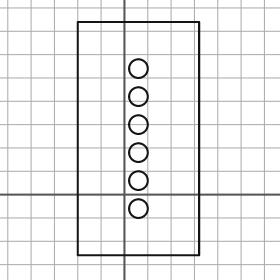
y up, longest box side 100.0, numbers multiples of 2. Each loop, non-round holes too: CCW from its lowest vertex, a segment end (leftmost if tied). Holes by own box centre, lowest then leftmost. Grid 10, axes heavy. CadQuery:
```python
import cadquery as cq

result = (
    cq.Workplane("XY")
    .moveTo(-20.0, -26.0)
    .lineTo(32.0, -26.0)
    .lineTo(32.0, 74.0)
    .lineTo(-20.0, 74.0)
    .close()
    .moveTo(6.0, -6.0)
    .circle(4.0)
    .moveTo(6.0, 6.0)
    .circle(4.0)
    .moveTo(6.0, 18.0)
    .circle(4.0)
    .moveTo(6.0, 30.0)
    .circle(4.0)
    .moveTo(6.0, 42.0)
    .circle(4.0)
    .moveTo(6.0, 54.0)
    .circle(4.0)
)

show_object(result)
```